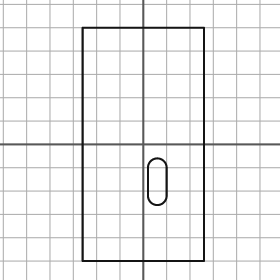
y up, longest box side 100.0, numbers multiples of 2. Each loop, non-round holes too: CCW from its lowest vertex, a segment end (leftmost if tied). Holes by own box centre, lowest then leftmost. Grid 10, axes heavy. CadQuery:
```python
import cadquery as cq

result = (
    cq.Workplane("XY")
    .moveTo(-26.0, -50.0)
    .lineTo(26.0, -50.0)
    .lineTo(26.0, 50.0)
    .lineTo(-26.0, 50.0)
    .close()
    .moveTo(2.0, -22.0)
    .threePointArc((6.0, -26.0), (10.0, -22.0))
    .lineTo(10.0, -10.0)
    .threePointArc((6.0, -6.0), (2.0, -10.0))
    .close()
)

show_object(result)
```